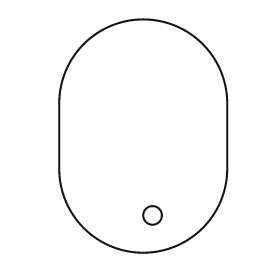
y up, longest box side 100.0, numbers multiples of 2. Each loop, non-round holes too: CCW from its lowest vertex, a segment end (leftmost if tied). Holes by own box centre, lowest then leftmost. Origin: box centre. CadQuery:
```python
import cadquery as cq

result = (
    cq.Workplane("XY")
    .moveTo(-36.0, -14.0)
    .threePointArc((0.0, -50.0), (36.0, -14.0))
    .lineTo(36.0, 14.0)
    .threePointArc((0.0, 50.0), (-36.0, 14.0))
    .close()
    .moveTo(4.0, -34.0)
    .circle(4.0)
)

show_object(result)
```